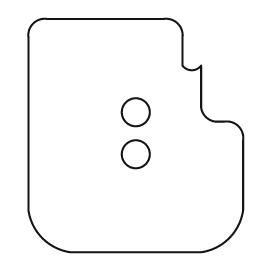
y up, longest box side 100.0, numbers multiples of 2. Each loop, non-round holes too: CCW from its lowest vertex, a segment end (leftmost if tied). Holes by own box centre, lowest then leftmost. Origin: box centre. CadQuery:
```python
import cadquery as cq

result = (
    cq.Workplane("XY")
    .moveTo(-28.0, -50.0)
    .lineTo(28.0, -50.0)
    .threePointArc((40.0, -44.0), (46.0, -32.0))
    .lineTo(46.0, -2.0)
    .threePointArc((44.0, 4.0), (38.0, 6.0))
    .lineTo(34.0, 6.0)
    .threePointArc((30.0, 8.0), (28.0, 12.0))
    .lineTo(28.0, 30.0)
    .threePointArc((24.0, 28.0), (20.0, 30.0))
    .lineTo(20.0, 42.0)
    .threePointArc((18.0, 48.0), (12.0, 50.0))
    .lineTo(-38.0, 50.0)
    .threePointArc((-44.0, 48.0), (-46.0, 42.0))
    .lineTo(-46.0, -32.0)
    .threePointArc((-40.0, -44.0), (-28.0, -50.0))
    .close()
    .moveTo(0.0, -8.0)
    .circle(6.0)
    .moveTo(0.0, 10.0)
    .circle(6.0)
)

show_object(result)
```